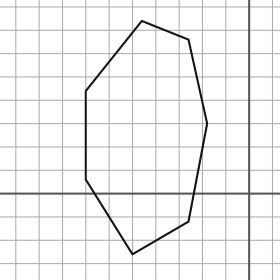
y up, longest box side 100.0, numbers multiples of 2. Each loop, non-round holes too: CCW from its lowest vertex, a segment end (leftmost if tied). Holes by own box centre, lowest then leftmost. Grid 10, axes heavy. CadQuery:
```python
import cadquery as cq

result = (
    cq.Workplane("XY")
    .moveTo(-50.0, -26.0)
    .lineTo(-26.0, -12.0)
    .lineTo(-18.0, 30.0)
    .lineTo(-26.0, 66.0)
    .lineTo(-46.0, 74.0)
    .lineTo(-70.0, 44.0)
    .lineTo(-70.0, 6.0)
    .close()
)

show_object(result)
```